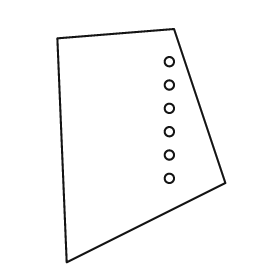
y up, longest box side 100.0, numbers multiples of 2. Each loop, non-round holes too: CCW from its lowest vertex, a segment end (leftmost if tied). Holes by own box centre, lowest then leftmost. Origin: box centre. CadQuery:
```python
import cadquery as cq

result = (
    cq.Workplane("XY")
    .moveTo(-32.0, -50.0)
    .lineTo(36.0, -16.0)
    .lineTo(14.0, 50.0)
    .lineTo(-36.0, 46.0)
    .close()
    .moveTo(12.0, -14.0)
    .circle(2.0)
    .moveTo(12.0, -4.0)
    .circle(2.0)
    .moveTo(12.0, 6.0)
    .circle(2.0)
    .moveTo(12.0, 16.0)
    .circle(2.0)
    .moveTo(12.0, 26.0)
    .circle(2.0)
    .moveTo(12.0, 36.0)
    .circle(2.0)
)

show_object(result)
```